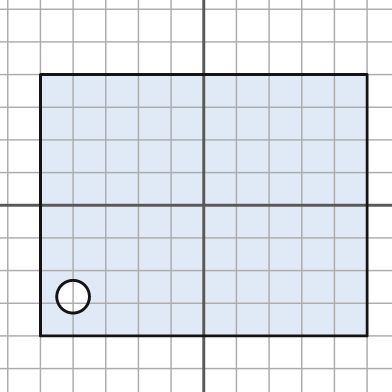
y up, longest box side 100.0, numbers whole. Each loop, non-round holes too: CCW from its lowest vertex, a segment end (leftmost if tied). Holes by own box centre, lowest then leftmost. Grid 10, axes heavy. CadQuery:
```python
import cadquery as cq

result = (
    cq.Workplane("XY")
    .moveTo(-50.0, -40.0)
    .lineTo(50.0, -40.0)
    .lineTo(50.0, 40.0)
    .lineTo(-50.0, 40.0)
    .close()
    .moveTo(-40.0, -28.0)
    .circle(5.0)
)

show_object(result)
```